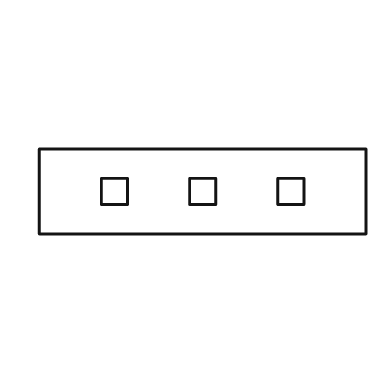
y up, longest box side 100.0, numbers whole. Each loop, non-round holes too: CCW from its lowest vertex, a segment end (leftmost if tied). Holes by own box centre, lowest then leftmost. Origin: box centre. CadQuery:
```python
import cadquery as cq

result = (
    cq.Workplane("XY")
    .moveTo(-50.0, -13.0)
    .lineTo(50.0, -13.0)
    .lineTo(50.0, 13.0)
    .lineTo(-50.0, 13.0)
    .close()
    .moveTo(-31.0, -4.0)
    .lineTo(-23.0, -4.0)
    .lineTo(-23.0, 4.0)
    .lineTo(-31.0, 4.0)
    .close()
    .moveTo(-4.0, -4.0)
    .lineTo(4.0, -4.0)
    .lineTo(4.0, 4.0)
    .lineTo(-4.0, 4.0)
    .close()
    .moveTo(23.0, -4.0)
    .lineTo(31.0, -4.0)
    .lineTo(31.0, 4.0)
    .lineTo(23.0, 4.0)
    .close()
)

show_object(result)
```